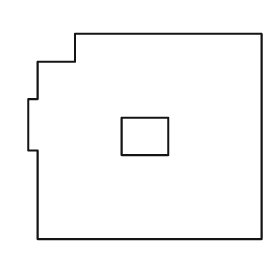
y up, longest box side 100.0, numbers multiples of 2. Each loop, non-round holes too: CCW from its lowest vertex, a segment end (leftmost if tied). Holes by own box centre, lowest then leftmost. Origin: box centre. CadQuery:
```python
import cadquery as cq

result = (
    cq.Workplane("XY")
    .moveTo(-46.0, -44.0)
    .lineTo(50.0, -44.0)
    .lineTo(50.0, 44.0)
    .lineTo(-30.0, 44.0)
    .lineTo(-30.0, 32.0)
    .lineTo(-46.0, 32.0)
    .lineTo(-46.0, 16.0)
    .lineTo(-50.0, 16.0)
    .lineTo(-50.0, -6.0)
    .lineTo(-46.0, -6.0)
    .close()
    .moveTo(-10.0, -8.0)
    .lineTo(10.0, -8.0)
    .lineTo(10.0, 8.0)
    .lineTo(-10.0, 8.0)
    .close()
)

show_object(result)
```